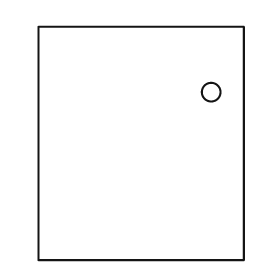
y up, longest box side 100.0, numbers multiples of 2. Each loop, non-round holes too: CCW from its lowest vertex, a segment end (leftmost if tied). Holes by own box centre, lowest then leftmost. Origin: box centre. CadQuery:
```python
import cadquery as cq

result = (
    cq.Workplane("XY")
    .moveTo(-44.0, -50.0)
    .lineTo(44.0, -50.0)
    .lineTo(44.0, 50.0)
    .lineTo(-44.0, 50.0)
    .close()
    .moveTo(30.0, 22.0)
    .circle(4.0)
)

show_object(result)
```